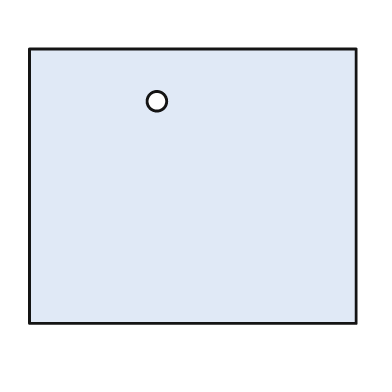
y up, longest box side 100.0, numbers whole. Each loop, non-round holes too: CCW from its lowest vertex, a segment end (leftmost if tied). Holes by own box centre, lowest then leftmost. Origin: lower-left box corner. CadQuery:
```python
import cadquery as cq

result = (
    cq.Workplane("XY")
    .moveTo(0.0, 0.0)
    .lineTo(100.0, 0.0)
    .lineTo(100.0, 84.0)
    .lineTo(0.0, 84.0)
    .close()
    .moveTo(39.0, 68.0)
    .circle(3.0)
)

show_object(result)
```